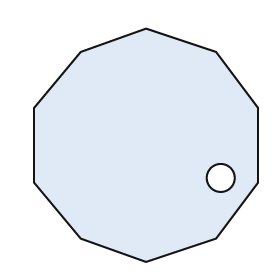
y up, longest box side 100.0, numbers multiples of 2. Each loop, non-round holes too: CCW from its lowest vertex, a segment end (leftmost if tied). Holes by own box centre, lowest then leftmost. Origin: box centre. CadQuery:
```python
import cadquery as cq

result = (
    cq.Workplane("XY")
    .moveTo(0.0, -50.0)
    .lineTo(30.0, -40.0)
    .lineTo(48.0, -16.0)
    .lineTo(48.0, 16.0)
    .lineTo(30.0, 40.0)
    .lineTo(0.0, 50.0)
    .lineTo(-28.0, 40.0)
    .lineTo(-48.0, 16.0)
    .lineTo(-48.0, -16.0)
    .lineTo(-28.0, -40.0)
    .close()
    .moveTo(32.0, -14.0)
    .circle(6.0)
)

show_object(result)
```